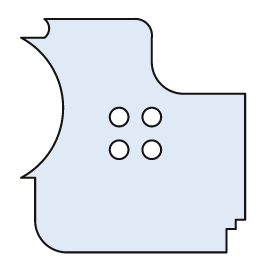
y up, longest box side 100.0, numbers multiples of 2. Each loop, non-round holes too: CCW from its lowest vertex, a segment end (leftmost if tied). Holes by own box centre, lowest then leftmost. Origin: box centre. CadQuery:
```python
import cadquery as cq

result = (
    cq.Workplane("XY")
    .moveTo(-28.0, -50.0)
    .lineTo(40.0, -50.0)
    .lineTo(40.0, -40.0)
    .lineTo(44.0, -40.0)
    .lineTo(44.0, -36.0)
    .lineTo(48.0, -36.0)
    .lineTo(48.0, 18.0)
    .lineTo(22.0, 18.0)
    .threePointArc((12.0, 22.0), (8.0, 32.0))
    .lineTo(8.0, 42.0)
    .threePointArc((6.0, 48.0), (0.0, 50.0))
    .lineTo(-38.0, 50.0)
    .threePointArc((-36.0, 46.0), (-38.0, 42.0))
    .lineTo(-48.0, 42.0)
    .threePointArc((-30.0, 12.0), (-48.0, -18.0))
    .lineTo(-42.0, -18.0)
    .lineTo(-42.0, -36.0)
    .threePointArc((-38.0, -46.0), (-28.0, -50.0))
    .close()
    .moveTo(-6.0, -6.0)
    .circle(4.0)
    .moveTo(8.0, -6.0)
    .circle(4.0)
    .moveTo(-6.0, 8.0)
    .circle(4.0)
    .moveTo(8.0, 8.0)
    .circle(4.0)
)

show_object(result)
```